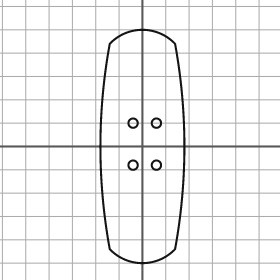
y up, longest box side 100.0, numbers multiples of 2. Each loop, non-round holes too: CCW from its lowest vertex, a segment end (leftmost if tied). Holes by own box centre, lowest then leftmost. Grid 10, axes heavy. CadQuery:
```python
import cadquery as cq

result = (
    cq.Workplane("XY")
    .moveTo(-14.0, -44.0)
    .threePointArc((0.0, -50.0), (14.0, -44.0))
    .threePointArc((18.0, 0.0), (14.0, 44.0))
    .threePointArc((0.0, 50.0), (-14.0, 44.0))
    .threePointArc((-18.0, 0.0), (-14.0, -44.0))
    .close()
    .moveTo(-4.0, -8.0)
    .circle(2.0)
    .moveTo(6.0, -8.0)
    .circle(2.0)
    .moveTo(-4.0, 10.0)
    .circle(2.0)
    .moveTo(6.0, 10.0)
    .circle(2.0)
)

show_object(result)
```